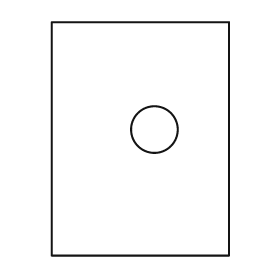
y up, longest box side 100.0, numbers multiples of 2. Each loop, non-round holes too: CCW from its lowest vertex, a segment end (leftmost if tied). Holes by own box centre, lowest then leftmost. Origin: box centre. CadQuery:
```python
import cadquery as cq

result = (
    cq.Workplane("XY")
    .moveTo(-38.0, -50.0)
    .lineTo(38.0, -50.0)
    .lineTo(38.0, 50.0)
    .lineTo(-38.0, 50.0)
    .close()
    .moveTo(6.0, 4.0)
    .circle(10.0)
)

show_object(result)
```